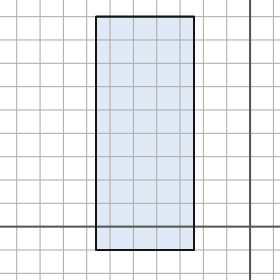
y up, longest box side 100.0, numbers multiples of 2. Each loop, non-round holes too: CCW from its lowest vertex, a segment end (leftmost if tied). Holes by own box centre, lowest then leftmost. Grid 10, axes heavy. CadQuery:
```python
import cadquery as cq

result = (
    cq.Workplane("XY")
    .moveTo(-66.0, -10.0)
    .lineTo(-24.0, -10.0)
    .lineTo(-24.0, 90.0)
    .lineTo(-66.0, 90.0)
    .close()
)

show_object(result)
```